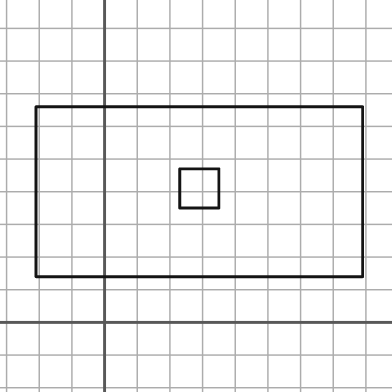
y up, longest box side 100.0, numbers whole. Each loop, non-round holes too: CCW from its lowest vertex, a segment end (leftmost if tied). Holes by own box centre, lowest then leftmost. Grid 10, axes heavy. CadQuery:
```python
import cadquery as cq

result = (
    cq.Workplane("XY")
    .moveTo(-21.0, 14.0)
    .lineTo(79.0, 14.0)
    .lineTo(79.0, 66.0)
    .lineTo(-21.0, 66.0)
    .close()
    .moveTo(23.0, 35.0)
    .lineTo(35.0, 35.0)
    .lineTo(35.0, 47.0)
    .lineTo(23.0, 47.0)
    .close()
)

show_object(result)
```